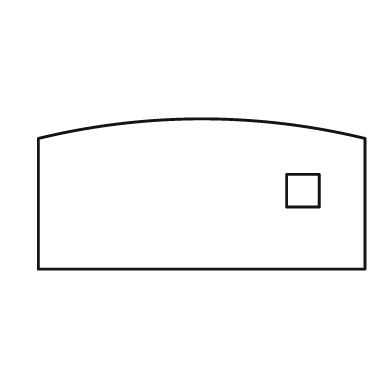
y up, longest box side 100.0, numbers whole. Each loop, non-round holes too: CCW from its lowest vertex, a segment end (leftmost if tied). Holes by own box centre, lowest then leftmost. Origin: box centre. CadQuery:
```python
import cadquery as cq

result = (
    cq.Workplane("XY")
    .moveTo(-50.0, -23.0)
    .lineTo(50.0, -23.0)
    .lineTo(50.0, 17.0)
    .threePointArc((0.0, 23.0), (-50.0, 17.0))
    .close()
    .moveTo(26.0, -4.0)
    .lineTo(36.0, -4.0)
    .lineTo(36.0, 6.0)
    .lineTo(26.0, 6.0)
    .close()
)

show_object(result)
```